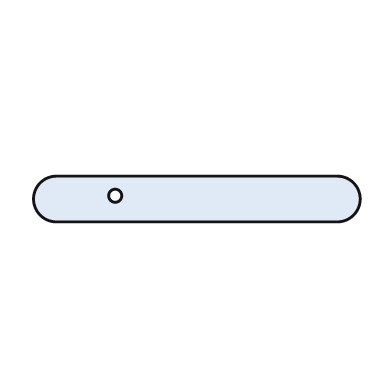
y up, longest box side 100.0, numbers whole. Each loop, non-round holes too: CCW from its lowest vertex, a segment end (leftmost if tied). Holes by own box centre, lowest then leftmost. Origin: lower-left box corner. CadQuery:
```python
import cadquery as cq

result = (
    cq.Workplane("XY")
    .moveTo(7.0, 0.0)
    .lineTo(93.0, 0.0)
    .threePointArc((100.0, 7.0), (93.0, 14.0))
    .lineTo(7.0, 14.0)
    .threePointArc((0.0, 7.0), (7.0, 0.0))
    .close()
    .moveTo(25.0, 8.0)
    .circle(2.0)
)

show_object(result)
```